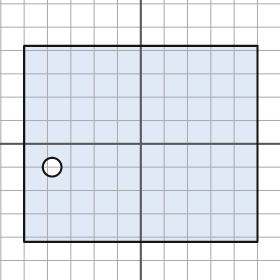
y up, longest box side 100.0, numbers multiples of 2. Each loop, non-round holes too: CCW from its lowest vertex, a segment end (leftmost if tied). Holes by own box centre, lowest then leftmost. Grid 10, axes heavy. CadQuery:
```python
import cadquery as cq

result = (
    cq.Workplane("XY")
    .moveTo(-50.0, -42.0)
    .lineTo(50.0, -42.0)
    .lineTo(50.0, 42.0)
    .lineTo(-50.0, 42.0)
    .close()
    .moveTo(-38.0, -10.0)
    .circle(4.0)
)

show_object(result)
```